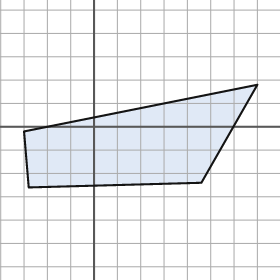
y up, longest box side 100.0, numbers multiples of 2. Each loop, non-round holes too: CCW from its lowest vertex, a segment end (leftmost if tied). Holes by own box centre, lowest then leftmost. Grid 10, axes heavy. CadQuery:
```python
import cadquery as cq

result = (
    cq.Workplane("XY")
    .moveTo(-28.0, -26.0)
    .lineTo(46.0, -24.0)
    .lineTo(70.0, 18.0)
    .lineTo(-30.0, -2.0)
    .close()
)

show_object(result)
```